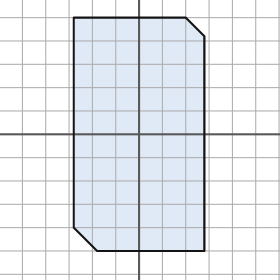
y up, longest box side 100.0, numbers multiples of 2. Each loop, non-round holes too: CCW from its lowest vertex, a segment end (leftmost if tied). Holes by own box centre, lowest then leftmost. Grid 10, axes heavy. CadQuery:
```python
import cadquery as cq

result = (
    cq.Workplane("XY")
    .moveTo(-18.0, -50.0)
    .lineTo(28.0, -50.0)
    .lineTo(28.0, 42.0)
    .lineTo(20.0, 50.0)
    .lineTo(-28.0, 50.0)
    .lineTo(-28.0, -40.0)
    .close()
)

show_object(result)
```